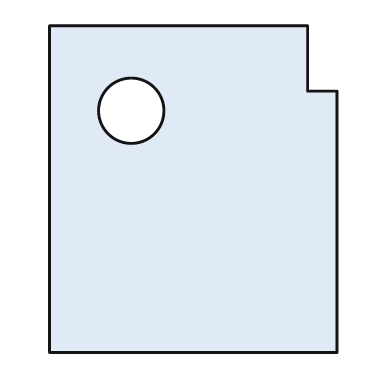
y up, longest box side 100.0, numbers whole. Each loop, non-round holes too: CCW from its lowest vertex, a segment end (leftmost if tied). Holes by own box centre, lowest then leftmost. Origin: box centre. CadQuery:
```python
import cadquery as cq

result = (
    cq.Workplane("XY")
    .moveTo(-44.0, -50.0)
    .lineTo(44.0, -50.0)
    .lineTo(44.0, 30.0)
    .lineTo(35.0, 30.0)
    .lineTo(35.0, 50.0)
    .lineTo(-44.0, 50.0)
    .close()
    .moveTo(-19.0, 24.0)
    .circle(10.0)
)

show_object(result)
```